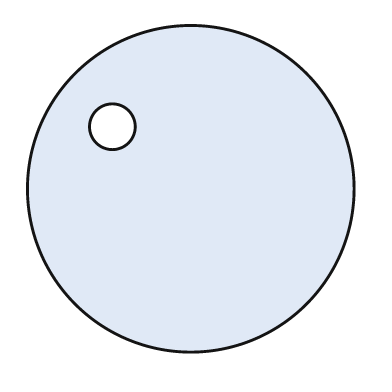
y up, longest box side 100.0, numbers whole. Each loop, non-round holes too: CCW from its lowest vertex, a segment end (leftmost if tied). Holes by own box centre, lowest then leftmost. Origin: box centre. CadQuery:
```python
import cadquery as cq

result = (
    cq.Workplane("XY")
    .moveTo(0.0, 0.0)
    .circle(50.0)
    .moveTo(-24.0, 19.0)
    .circle(7.0)
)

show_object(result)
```